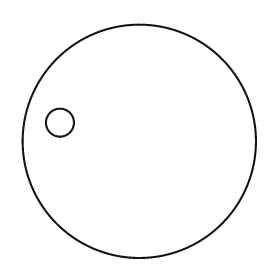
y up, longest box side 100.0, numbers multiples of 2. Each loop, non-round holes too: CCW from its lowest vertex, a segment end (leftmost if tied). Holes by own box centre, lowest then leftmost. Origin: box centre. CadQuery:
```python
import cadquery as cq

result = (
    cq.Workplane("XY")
    .moveTo(0.0, 0.0)
    .circle(50.0)
    .moveTo(-34.0, 8.0)
    .circle(6.0)
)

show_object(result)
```